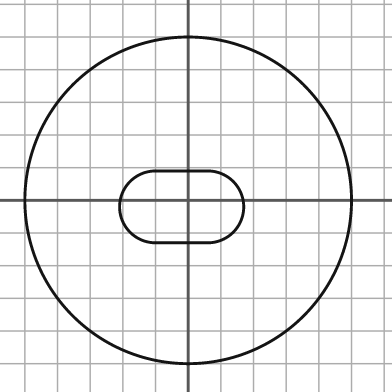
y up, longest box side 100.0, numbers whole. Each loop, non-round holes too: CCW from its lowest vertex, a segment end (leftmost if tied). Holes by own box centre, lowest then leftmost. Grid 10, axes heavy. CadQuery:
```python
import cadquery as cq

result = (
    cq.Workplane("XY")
    .moveTo(0.0, 0.0)
    .circle(50.0)
    .moveTo(-10.0, -13.0)
    .lineTo(6.0, -13.0)
    .threePointArc((17.0, -2.0), (6.0, 9.0))
    .lineTo(-10.0, 9.0)
    .threePointArc((-21.0, -2.0), (-10.0, -13.0))
    .close()
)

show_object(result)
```